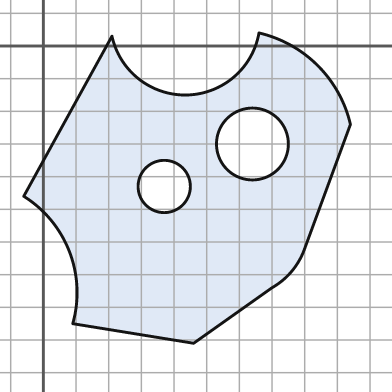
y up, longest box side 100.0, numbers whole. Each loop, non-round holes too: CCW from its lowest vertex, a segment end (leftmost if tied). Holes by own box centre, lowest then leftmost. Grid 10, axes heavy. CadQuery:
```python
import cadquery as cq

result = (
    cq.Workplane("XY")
    .moveTo(46.0, -91.0)
    .lineTo(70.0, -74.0)
    .threePointArc((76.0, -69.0), (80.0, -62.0))
    .lineTo(94.0, -24.0)
    .threePointArc((84.0, -6.0), (66.0, 4.0))
    .threePointArc((44.0, -15.0), (21.0, 3.0))
    .lineTo(-6.0, -46.0)
    .threePointArc((8.0, -63.0), (9.0, -85.0))
    .close()
    .moveTo(37.0, -43.0)
    .circle(8.0)
    .moveTo(64.0, -30.0)
    .circle(11.0)
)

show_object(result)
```